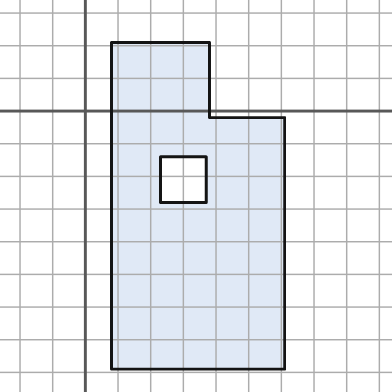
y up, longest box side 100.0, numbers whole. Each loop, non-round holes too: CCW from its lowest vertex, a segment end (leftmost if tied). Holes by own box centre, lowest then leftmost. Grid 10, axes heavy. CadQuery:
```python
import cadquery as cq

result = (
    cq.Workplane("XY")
    .moveTo(8.0, -79.0)
    .lineTo(61.0, -79.0)
    .lineTo(61.0, -2.0)
    .lineTo(38.0, -2.0)
    .lineTo(38.0, 21.0)
    .lineTo(8.0, 21.0)
    .close()
    .moveTo(23.0, -28.0)
    .lineTo(37.0, -28.0)
    .lineTo(37.0, -14.0)
    .lineTo(23.0, -14.0)
    .close()
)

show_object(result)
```